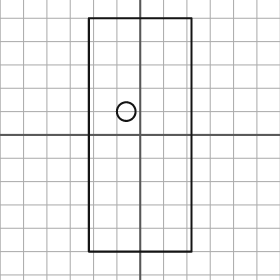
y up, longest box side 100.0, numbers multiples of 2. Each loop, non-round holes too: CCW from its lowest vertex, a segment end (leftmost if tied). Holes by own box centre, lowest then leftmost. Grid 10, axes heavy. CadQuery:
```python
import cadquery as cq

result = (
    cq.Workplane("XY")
    .moveTo(-22.0, -50.0)
    .lineTo(22.0, -50.0)
    .lineTo(22.0, 50.0)
    .lineTo(-22.0, 50.0)
    .close()
    .moveTo(-6.0, 10.0)
    .circle(4.0)
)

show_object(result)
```